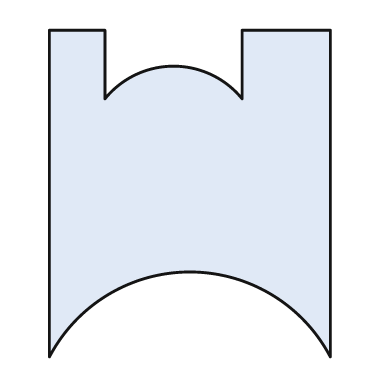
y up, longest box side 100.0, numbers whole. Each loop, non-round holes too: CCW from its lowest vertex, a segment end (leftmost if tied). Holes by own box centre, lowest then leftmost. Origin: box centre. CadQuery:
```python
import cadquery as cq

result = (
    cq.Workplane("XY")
    .moveTo(-43.0, -50.0)
    .threePointArc((0.0, -24.0), (43.0, -50.0))
    .lineTo(43.0, 50.0)
    .lineTo(16.0, 50.0)
    .lineTo(16.0, 29.0)
    .threePointArc((-5.0, 39.0), (-26.0, 29.0))
    .lineTo(-26.0, 50.0)
    .lineTo(-43.0, 50.0)
    .close()
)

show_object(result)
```